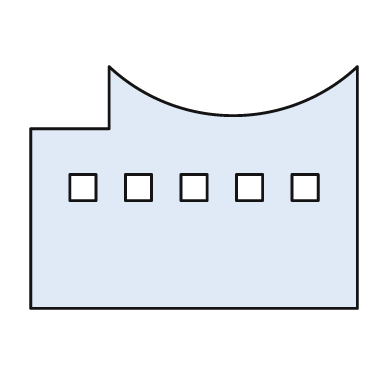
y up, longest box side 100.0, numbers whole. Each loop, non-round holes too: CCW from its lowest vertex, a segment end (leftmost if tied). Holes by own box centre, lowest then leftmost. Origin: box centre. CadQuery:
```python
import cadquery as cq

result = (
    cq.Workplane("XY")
    .moveTo(-50.0, -37.0)
    .lineTo(50.0, -37.0)
    .lineTo(50.0, 37.0)
    .threePointArc((12.0, 22.0), (-26.0, 37.0))
    .lineTo(-26.0, 18.0)
    .lineTo(-50.0, 18.0)
    .close()
    .moveTo(-38.0, -4.0)
    .lineTo(-30.0, -4.0)
    .lineTo(-30.0, 4.0)
    .lineTo(-38.0, 4.0)
    .close()
    .moveTo(-21.0, -4.0)
    .lineTo(-13.0, -4.0)
    .lineTo(-13.0, 4.0)
    .lineTo(-21.0, 4.0)
    .close()
    .moveTo(-4.0, -4.0)
    .lineTo(4.0, -4.0)
    .lineTo(4.0, 4.0)
    .lineTo(-4.0, 4.0)
    .close()
    .moveTo(13.0, -4.0)
    .lineTo(21.0, -4.0)
    .lineTo(21.0, 4.0)
    .lineTo(13.0, 4.0)
    .close()
    .moveTo(30.0, -4.0)
    .lineTo(38.0, -4.0)
    .lineTo(38.0, 4.0)
    .lineTo(30.0, 4.0)
    .close()
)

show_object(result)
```